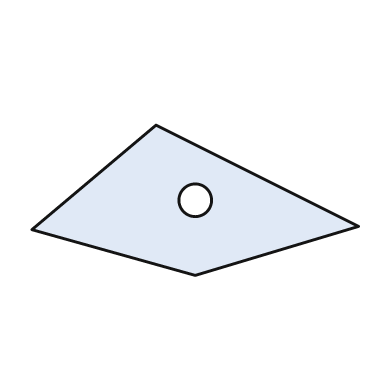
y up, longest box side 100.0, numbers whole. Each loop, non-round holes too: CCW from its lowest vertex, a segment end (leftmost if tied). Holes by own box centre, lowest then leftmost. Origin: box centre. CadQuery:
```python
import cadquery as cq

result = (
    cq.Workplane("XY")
    .moveTo(0.0, -23.0)
    .lineTo(50.0, -8.0)
    .lineTo(-12.0, 23.0)
    .lineTo(-50.0, -9.0)
    .close()
    .moveTo(0.0, 0.0)
    .circle(5.0)
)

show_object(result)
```